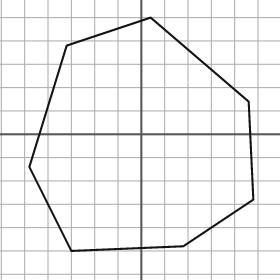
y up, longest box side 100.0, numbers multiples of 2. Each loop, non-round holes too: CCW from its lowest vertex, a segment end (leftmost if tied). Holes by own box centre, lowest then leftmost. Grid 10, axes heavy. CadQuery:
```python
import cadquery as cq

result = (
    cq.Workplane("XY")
    .moveTo(-30.0, -50.0)
    .lineTo(18.0, -48.0)
    .lineTo(48.0, -28.0)
    .lineTo(46.0, 14.0)
    .lineTo(4.0, 50.0)
    .lineTo(-32.0, 38.0)
    .lineTo(-48.0, -14.0)
    .close()
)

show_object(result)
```